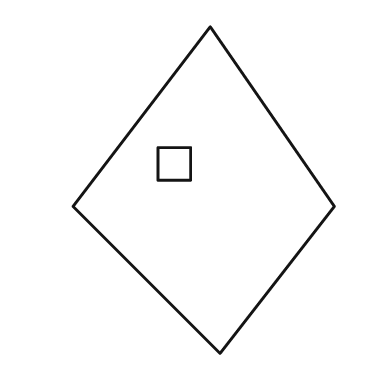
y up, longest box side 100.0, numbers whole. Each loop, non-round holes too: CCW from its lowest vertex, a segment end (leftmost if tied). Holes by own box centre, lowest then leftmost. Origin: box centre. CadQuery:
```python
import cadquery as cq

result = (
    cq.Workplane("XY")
    .moveTo(5.0, -50.0)
    .lineTo(40.0, -5.0)
    .lineTo(2.0, 50.0)
    .lineTo(-40.0, -5.0)
    .close()
    .moveTo(-14.0, 3.0)
    .lineTo(-4.0, 3.0)
    .lineTo(-4.0, 13.0)
    .lineTo(-14.0, 13.0)
    .close()
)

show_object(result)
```